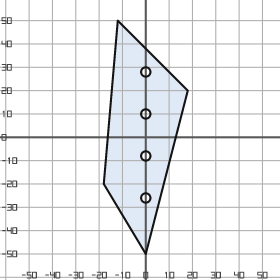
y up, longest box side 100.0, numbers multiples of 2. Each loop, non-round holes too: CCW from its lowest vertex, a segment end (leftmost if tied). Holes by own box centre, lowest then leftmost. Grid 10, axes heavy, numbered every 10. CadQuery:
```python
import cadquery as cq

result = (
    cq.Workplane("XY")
    .moveTo(0.0, -50.0)
    .lineTo(18.0, 20.0)
    .lineTo(-12.0, 50.0)
    .lineTo(-18.0, -20.0)
    .close()
    .moveTo(0.0, -26.0)
    .circle(2.0)
    .moveTo(0.0, -8.0)
    .circle(2.0)
    .moveTo(0.0, 10.0)
    .circle(2.0)
    .moveTo(0.0, 28.0)
    .circle(2.0)
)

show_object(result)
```